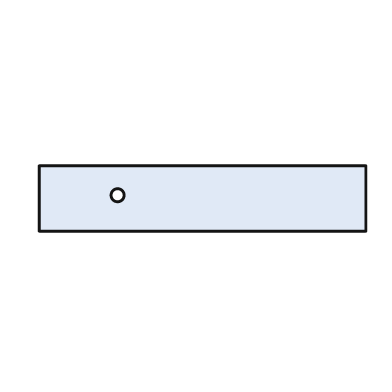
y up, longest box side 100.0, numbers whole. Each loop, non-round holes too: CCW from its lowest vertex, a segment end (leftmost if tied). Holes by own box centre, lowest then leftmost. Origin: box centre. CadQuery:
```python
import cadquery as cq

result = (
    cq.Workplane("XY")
    .moveTo(-50.0, -10.0)
    .lineTo(50.0, -10.0)
    .lineTo(50.0, 10.0)
    .lineTo(-50.0, 10.0)
    .close()
    .moveTo(-26.0, 1.0)
    .circle(2.0)
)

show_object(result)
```